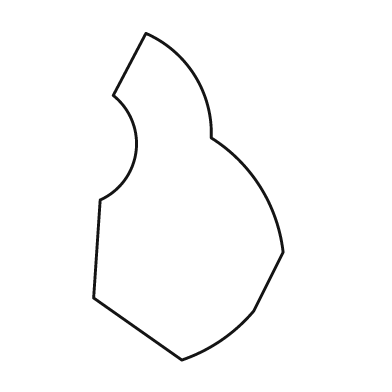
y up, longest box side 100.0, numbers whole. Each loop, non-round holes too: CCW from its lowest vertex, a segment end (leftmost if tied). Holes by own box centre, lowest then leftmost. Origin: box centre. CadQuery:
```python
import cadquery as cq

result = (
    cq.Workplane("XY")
    .moveTo(-2.0, -50.0)
    .threePointArc((10.0, -44.0), (20.0, -35.0))
    .lineTo(29.0, -17.0)
    .threePointArc((22.0, 3.0), (7.0, 18.0))
    .threePointArc((2.0, 37.0), (-13.0, 50.0))
    .lineTo(-23.0, 31.0)
    .threePointArc((-16.0, 14.0), (-27.0, -1.0))
    .lineTo(-29.0, -31.0)
    .close()
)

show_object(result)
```